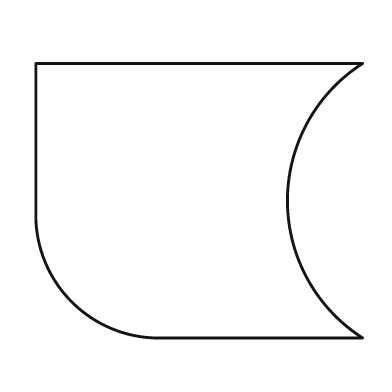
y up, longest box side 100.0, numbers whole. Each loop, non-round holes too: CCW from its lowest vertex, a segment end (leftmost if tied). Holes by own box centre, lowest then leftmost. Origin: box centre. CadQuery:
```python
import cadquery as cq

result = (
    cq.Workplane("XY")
    .moveTo(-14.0, -42.0)
    .lineTo(50.0, -42.0)
    .threePointArc((27.0, 0.0), (50.0, 42.0))
    .lineTo(-50.0, 42.0)
    .lineTo(-50.0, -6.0)
    .threePointArc((-39.0, -31.0), (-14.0, -42.0))
    .close()
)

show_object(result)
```